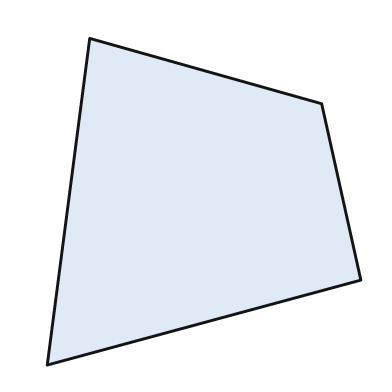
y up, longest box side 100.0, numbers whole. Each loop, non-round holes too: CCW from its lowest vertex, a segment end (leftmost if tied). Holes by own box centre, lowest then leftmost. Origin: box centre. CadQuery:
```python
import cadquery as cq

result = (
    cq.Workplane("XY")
    .moveTo(-48.0, -50.0)
    .lineTo(48.0, -24.0)
    .lineTo(36.0, 30.0)
    .lineTo(-35.0, 50.0)
    .close()
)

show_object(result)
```